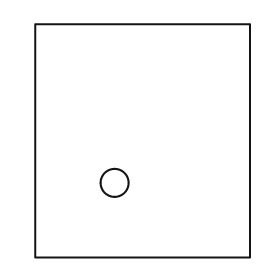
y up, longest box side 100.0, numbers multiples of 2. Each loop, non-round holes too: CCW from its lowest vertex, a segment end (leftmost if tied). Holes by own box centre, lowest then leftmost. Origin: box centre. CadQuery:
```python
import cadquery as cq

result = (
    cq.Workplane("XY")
    .moveTo(-46.0, -50.0)
    .lineTo(46.0, -50.0)
    .lineTo(46.0, 50.0)
    .lineTo(-46.0, 50.0)
    .close()
    .moveTo(-12.0, -18.0)
    .circle(6.0)
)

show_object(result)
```